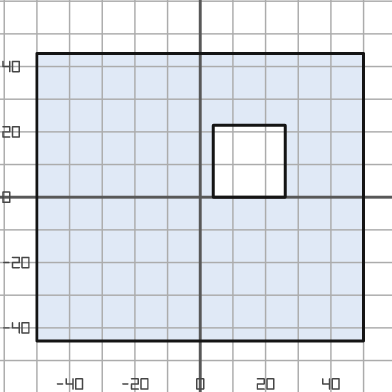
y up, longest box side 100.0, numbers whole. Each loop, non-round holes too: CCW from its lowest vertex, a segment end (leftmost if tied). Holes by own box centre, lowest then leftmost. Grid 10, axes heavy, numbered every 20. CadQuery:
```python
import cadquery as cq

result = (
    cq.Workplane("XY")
    .moveTo(-50.0, -44.0)
    .lineTo(50.0, -44.0)
    .lineTo(50.0, 44.0)
    .lineTo(-50.0, 44.0)
    .close()
    .moveTo(4.0, 0.0)
    .lineTo(26.0, 0.0)
    .lineTo(26.0, 22.0)
    .lineTo(4.0, 22.0)
    .close()
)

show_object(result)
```